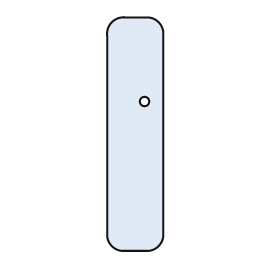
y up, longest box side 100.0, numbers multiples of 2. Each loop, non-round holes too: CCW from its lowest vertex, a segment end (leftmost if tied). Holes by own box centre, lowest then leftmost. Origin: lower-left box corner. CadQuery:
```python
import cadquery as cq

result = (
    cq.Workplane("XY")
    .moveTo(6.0, 0.0)
    .lineTo(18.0, 0.0)
    .threePointArc((22.0, 2.0), (24.0, 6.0))
    .lineTo(24.0, 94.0)
    .threePointArc((22.0, 98.0), (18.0, 100.0))
    .lineTo(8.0, 100.0)
    .threePointArc((2.0, 98.0), (0.0, 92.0))
    .lineTo(0.0, 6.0)
    .threePointArc((2.0, 2.0), (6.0, 0.0))
    .close()
    .moveTo(16.0, 64.0)
    .circle(2.0)
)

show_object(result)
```